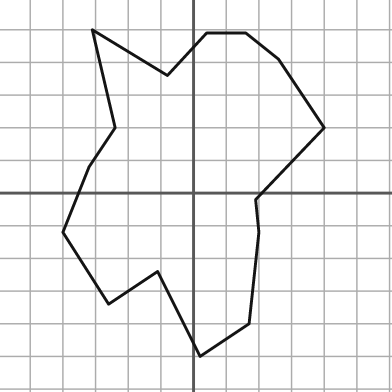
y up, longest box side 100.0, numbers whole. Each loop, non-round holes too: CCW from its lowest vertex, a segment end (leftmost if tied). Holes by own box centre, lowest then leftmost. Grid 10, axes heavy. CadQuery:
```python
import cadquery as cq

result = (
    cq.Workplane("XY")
    .moveTo(2.0, -50.0)
    .lineTo(17.0, -40.0)
    .lineTo(20.0, -12.0)
    .lineTo(19.0, -2.0)
    .lineTo(40.0, 20.0)
    .lineTo(26.0, 41.0)
    .lineTo(16.0, 49.0)
    .lineTo(4.0, 49.0)
    .lineTo(-8.0, 36.0)
    .lineTo(-31.0, 50.0)
    .lineTo(-24.0, 20.0)
    .lineTo(-32.0, 8.0)
    .lineTo(-40.0, -12.0)
    .lineTo(-26.0, -34.0)
    .lineTo(-11.0, -24.0)
    .close()
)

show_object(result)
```